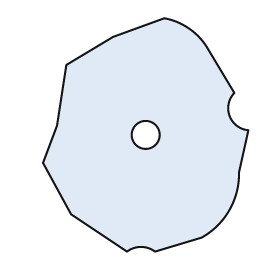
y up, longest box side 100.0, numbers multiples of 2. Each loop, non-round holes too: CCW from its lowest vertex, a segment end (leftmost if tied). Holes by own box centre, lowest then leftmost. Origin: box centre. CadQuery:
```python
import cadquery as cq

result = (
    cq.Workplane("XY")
    .moveTo(-8.0, -50.0)
    .threePointArc((-2.0, -48.0), (4.0, -50.0))
    .lineTo(24.0, -44.0)
    .threePointArc((36.0, -32.0), (40.0, -16.0))
    .lineTo(44.0, 2.0)
    .threePointArc((36.0, 8.0), (38.0, 18.0))
    .lineTo(26.0, 38.0)
    .threePointArc((18.0, 46.0), (8.0, 50.0))
    .lineTo(-14.0, 42.0)
    .lineTo(-34.0, 30.0)
    .lineTo(-38.0, 4.0)
    .lineTo(-44.0, -12.0)
    .lineTo(-32.0, -34.0)
    .close()
    .moveTo(0.0, 0.0)
    .circle(6.0)
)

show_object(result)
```